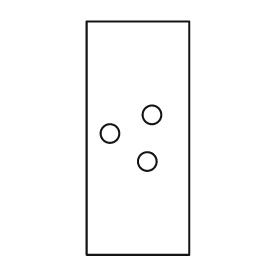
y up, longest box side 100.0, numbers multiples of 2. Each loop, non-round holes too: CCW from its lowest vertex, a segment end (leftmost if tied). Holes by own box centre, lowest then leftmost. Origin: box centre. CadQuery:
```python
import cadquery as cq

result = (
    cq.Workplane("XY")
    .moveTo(-22.0, -50.0)
    .lineTo(22.0, -50.0)
    .lineTo(22.0, 50.0)
    .lineTo(-22.0, 50.0)
    .close()
    .moveTo(4.0, -10.0)
    .circle(4.0)
    .moveTo(-12.0, 2.0)
    .circle(4.0)
    .moveTo(6.0, 10.0)
    .circle(4.0)
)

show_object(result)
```